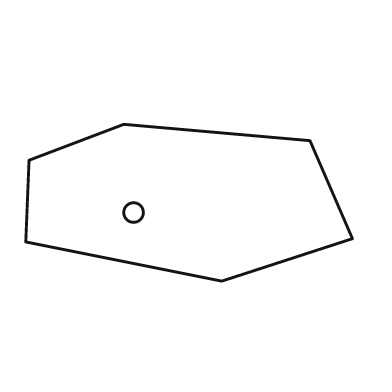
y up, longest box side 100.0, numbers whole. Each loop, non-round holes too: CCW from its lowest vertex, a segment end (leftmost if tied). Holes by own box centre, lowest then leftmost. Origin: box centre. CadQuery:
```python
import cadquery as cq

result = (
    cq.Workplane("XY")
    .moveTo(10.0, -24.0)
    .lineTo(50.0, -11.0)
    .lineTo(37.0, 19.0)
    .lineTo(-20.0, 24.0)
    .lineTo(-49.0, 13.0)
    .lineTo(-50.0, -12.0)
    .close()
    .moveTo(-17.0, -3.0)
    .circle(3.0)
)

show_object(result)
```